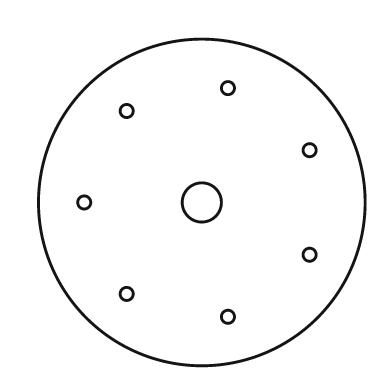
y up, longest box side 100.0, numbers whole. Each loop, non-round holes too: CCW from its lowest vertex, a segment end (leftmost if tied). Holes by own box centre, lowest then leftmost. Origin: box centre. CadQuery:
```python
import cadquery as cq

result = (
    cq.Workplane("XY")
    .moveTo(0.0, 0.0)
    .circle(50.0)
    .moveTo(8.0, -35.0)
    .circle(2.0)
    .moveTo(-23.0, -28.0)
    .circle(2.0)
    .moveTo(33.0, -16.0)
    .circle(2.0)
    .moveTo(-36.0, 0.0)
    .circle(2.0)
    .moveTo(0.0, 0.0)
    .circle(6.0)
    .moveTo(33.0, 16.0)
    .circle(2.0)
    .moveTo(-23.0, 28.0)
    .circle(2.0)
    .moveTo(8.0, 35.0)
    .circle(2.0)
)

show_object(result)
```